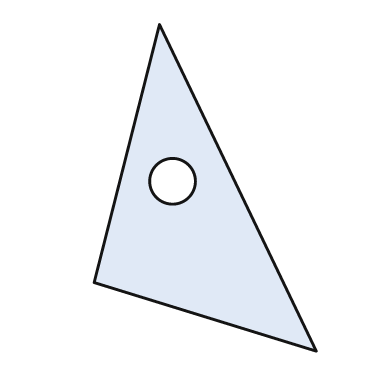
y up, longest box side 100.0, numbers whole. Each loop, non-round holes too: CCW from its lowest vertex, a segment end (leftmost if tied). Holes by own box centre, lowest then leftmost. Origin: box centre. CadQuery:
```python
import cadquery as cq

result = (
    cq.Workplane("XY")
    .moveTo(34.0, -50.0)
    .lineTo(-14.0, 50.0)
    .lineTo(-34.0, -29.0)
    .close()
    .moveTo(-10.0, 2.0)
    .circle(7.0)
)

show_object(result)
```